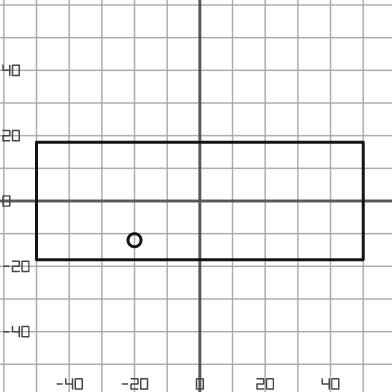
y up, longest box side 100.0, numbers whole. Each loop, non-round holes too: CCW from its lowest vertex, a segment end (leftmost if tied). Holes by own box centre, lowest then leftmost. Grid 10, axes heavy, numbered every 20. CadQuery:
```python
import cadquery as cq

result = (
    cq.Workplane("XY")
    .moveTo(-50.0, -18.0)
    .lineTo(50.0, -18.0)
    .lineTo(50.0, 18.0)
    .lineTo(-50.0, 18.0)
    .close()
    .moveTo(-20.0, -12.0)
    .circle(2.0)
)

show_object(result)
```